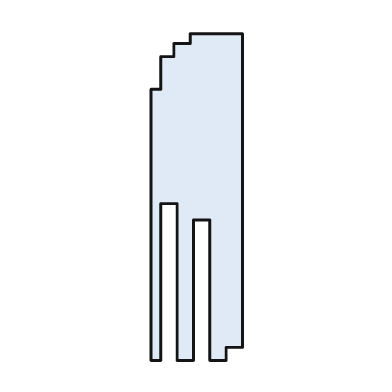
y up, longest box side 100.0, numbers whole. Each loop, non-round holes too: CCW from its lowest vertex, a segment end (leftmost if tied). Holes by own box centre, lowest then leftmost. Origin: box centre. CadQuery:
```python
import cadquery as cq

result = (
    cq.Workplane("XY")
    .moveTo(-14.0, -50.0)
    .lineTo(-11.0, -50.0)
    .lineTo(-11.0, -2.0)
    .lineTo(-6.0, -2.0)
    .lineTo(-6.0, -50.0)
    .lineTo(-1.0, -50.0)
    .lineTo(-1.0, -7.0)
    .lineTo(4.0, -7.0)
    .lineTo(4.0, -50.0)
    .lineTo(9.0, -50.0)
    .lineTo(9.0, -46.0)
    .lineTo(14.0, -46.0)
    .lineTo(14.0, 50.0)
    .lineTo(-2.0, 50.0)
    .lineTo(-2.0, 47.0)
    .lineTo(-7.0, 47.0)
    .lineTo(-7.0, 43.0)
    .lineTo(-11.0, 43.0)
    .lineTo(-11.0, 33.0)
    .lineTo(-14.0, 33.0)
    .close()
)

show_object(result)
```